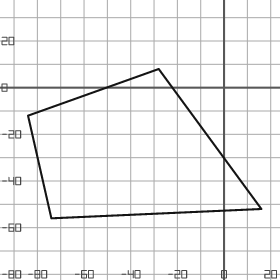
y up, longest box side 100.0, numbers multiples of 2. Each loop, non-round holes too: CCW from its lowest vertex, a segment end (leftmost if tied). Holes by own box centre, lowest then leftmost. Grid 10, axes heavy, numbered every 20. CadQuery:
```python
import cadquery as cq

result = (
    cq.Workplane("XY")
    .moveTo(-74.0, -56.0)
    .lineTo(16.0, -52.0)
    .lineTo(-28.0, 8.0)
    .lineTo(-84.0, -12.0)
    .close()
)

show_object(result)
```